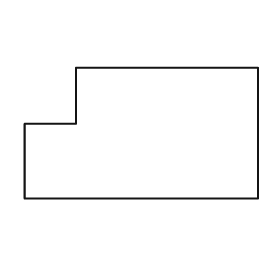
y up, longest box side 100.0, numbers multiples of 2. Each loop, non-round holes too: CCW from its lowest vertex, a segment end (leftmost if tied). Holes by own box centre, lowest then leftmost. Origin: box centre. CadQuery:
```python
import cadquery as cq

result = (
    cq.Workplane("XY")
    .moveTo(-50.0, -28.0)
    .lineTo(50.0, -28.0)
    .lineTo(50.0, 28.0)
    .lineTo(-28.0, 28.0)
    .lineTo(-28.0, 4.0)
    .lineTo(-50.0, 4.0)
    .close()
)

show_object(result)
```